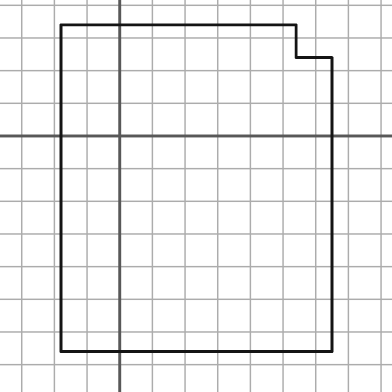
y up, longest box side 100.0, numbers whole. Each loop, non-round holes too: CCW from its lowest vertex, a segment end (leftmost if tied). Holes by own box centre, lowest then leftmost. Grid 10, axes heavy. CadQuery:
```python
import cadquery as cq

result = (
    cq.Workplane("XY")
    .moveTo(-18.0, -66.0)
    .lineTo(65.0, -66.0)
    .lineTo(65.0, 24.0)
    .lineTo(54.0, 24.0)
    .lineTo(54.0, 34.0)
    .lineTo(-18.0, 34.0)
    .close()
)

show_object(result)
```